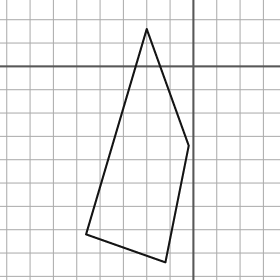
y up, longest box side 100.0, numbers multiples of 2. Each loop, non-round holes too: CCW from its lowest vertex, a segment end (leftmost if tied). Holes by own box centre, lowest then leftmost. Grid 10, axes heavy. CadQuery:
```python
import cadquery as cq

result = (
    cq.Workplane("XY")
    .moveTo(-12.0, -84.0)
    .lineTo(-2.0, -34.0)
    .lineTo(-20.0, 16.0)
    .lineTo(-46.0, -72.0)
    .close()
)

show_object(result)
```